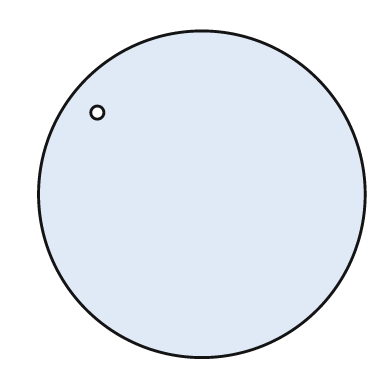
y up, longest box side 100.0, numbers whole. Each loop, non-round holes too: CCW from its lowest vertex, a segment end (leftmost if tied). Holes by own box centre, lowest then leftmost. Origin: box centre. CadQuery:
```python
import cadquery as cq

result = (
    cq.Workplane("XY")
    .moveTo(0.0, 0.0)
    .circle(50.0)
    .moveTo(-32.0, 25.0)
    .circle(2.0)
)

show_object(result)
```